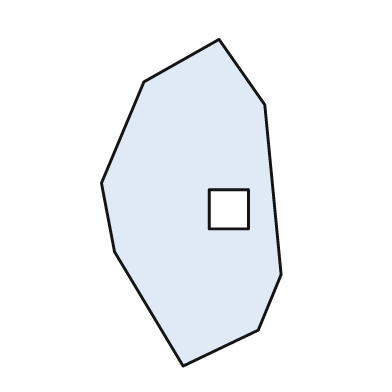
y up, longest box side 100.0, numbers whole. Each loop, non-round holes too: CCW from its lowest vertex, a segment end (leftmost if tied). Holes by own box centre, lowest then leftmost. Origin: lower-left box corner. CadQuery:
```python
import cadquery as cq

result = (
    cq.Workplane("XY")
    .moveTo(25.0, 0.0)
    .lineTo(48.0, 11.0)
    .lineTo(55.0, 28.0)
    .lineTo(50.0, 80.0)
    .lineTo(36.0, 100.0)
    .lineTo(13.0, 87.0)
    .lineTo(0.0, 56.0)
    .lineTo(4.0, 35.0)
    .close()
    .moveTo(33.0, 42.0)
    .lineTo(45.0, 42.0)
    .lineTo(45.0, 54.0)
    .lineTo(33.0, 54.0)
    .close()
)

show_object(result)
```